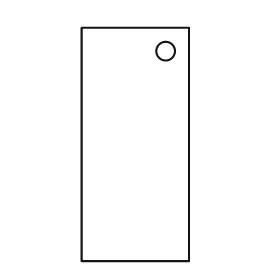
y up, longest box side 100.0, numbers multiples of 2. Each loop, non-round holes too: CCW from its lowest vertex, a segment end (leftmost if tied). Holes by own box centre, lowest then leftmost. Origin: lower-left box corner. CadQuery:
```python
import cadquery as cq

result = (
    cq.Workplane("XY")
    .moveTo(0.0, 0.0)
    .lineTo(46.0, 0.0)
    .lineTo(46.0, 100.0)
    .lineTo(0.0, 100.0)
    .close()
    .moveTo(36.0, 90.0)
    .circle(4.0)
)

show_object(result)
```